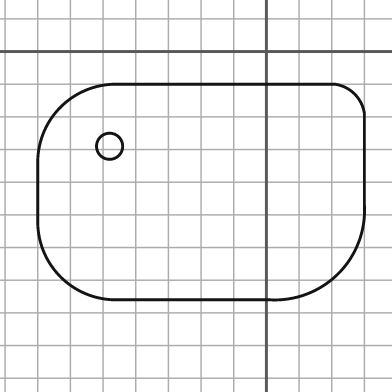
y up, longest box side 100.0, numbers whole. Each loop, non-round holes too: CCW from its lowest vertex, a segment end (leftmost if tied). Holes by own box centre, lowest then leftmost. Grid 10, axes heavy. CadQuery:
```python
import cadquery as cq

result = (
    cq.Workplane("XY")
    .moveTo(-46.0, -76.0)
    .lineTo(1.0, -76.0)
    .threePointArc((22.0, -68.0), (30.0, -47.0))
    .lineTo(30.0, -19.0)
    .threePointArc((27.0, -13.0), (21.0, -10.0))
    .lineTo(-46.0, -10.0)
    .threePointArc((-63.0, -17.0), (-70.0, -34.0))
    .lineTo(-70.0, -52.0)
    .threePointArc((-63.0, -69.0), (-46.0, -76.0))
    .close()
    .moveTo(-48.0, -29.0)
    .circle(4.0)
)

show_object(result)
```